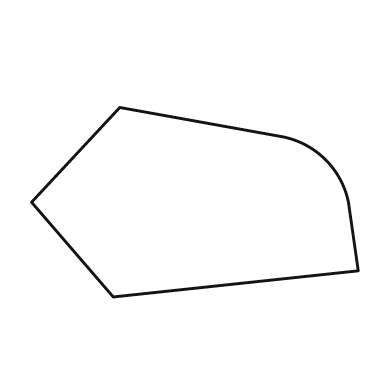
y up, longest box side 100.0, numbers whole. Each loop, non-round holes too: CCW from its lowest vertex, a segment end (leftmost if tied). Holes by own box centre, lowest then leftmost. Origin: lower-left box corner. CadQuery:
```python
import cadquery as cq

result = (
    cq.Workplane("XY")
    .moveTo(25.0, 0.0)
    .lineTo(100.0, 8.0)
    .lineTo(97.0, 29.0)
    .threePointArc((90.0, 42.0), (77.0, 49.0))
    .lineTo(27.0, 58.0)
    .lineTo(0.0, 29.0)
    .close()
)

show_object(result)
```